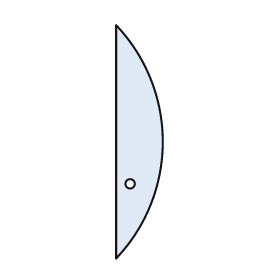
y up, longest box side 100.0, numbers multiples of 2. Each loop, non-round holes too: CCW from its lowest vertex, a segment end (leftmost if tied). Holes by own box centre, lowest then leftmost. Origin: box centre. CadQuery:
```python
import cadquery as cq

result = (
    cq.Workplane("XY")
    .moveTo(-10.0, -50.0)
    .threePointArc((10.0, 0.0), (-10.0, 50.0))
    .close()
    .moveTo(-4.0, -18.0)
    .circle(2.0)
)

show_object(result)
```